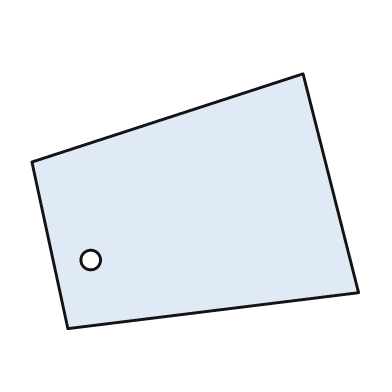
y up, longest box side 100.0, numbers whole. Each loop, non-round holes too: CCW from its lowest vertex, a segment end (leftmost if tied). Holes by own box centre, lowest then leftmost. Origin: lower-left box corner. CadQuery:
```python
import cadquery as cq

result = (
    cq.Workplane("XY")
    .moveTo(11.0, 0.0)
    .lineTo(100.0, 11.0)
    .lineTo(83.0, 78.0)
    .lineTo(0.0, 51.0)
    .close()
    .moveTo(18.0, 21.0)
    .circle(3.0)
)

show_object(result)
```